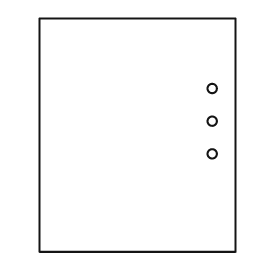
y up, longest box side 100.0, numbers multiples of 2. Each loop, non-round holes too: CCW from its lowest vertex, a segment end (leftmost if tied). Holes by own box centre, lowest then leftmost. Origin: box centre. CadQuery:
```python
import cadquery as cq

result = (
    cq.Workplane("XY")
    .moveTo(-42.0, -50.0)
    .lineTo(42.0, -50.0)
    .lineTo(42.0, 50.0)
    .lineTo(-42.0, 50.0)
    .close()
    .moveTo(32.0, -8.0)
    .circle(2.0)
    .moveTo(32.0, 6.0)
    .circle(2.0)
    .moveTo(32.0, 20.0)
    .circle(2.0)
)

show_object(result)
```